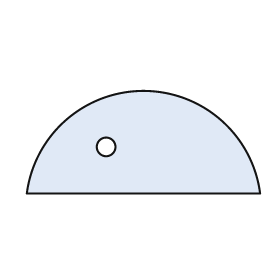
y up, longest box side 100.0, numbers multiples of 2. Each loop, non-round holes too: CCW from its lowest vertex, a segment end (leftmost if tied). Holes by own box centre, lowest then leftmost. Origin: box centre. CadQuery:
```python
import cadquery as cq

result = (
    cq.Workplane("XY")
    .moveTo(-50.0, -22.0)
    .lineTo(50.0, -22.0)
    .threePointArc((0.0, 22.0), (-50.0, -22.0))
    .close()
    .moveTo(-16.0, -2.0)
    .circle(4.0)
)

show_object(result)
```